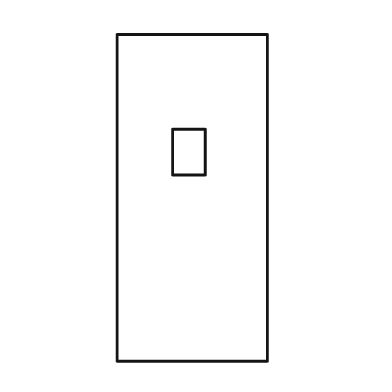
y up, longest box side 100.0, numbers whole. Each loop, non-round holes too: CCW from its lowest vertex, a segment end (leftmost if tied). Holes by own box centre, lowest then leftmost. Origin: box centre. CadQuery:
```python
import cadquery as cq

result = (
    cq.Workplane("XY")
    .moveTo(-23.0, -50.0)
    .lineTo(23.0, -50.0)
    .lineTo(23.0, 50.0)
    .lineTo(-23.0, 50.0)
    .close()
    .moveTo(-6.0, 7.0)
    .lineTo(4.0, 7.0)
    .lineTo(4.0, 21.0)
    .lineTo(-6.0, 21.0)
    .close()
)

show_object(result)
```